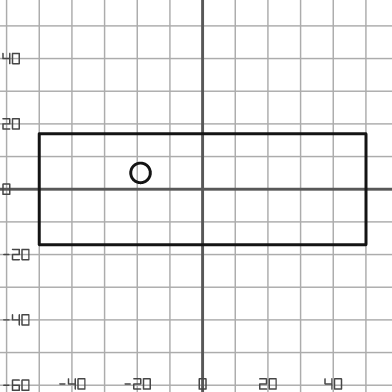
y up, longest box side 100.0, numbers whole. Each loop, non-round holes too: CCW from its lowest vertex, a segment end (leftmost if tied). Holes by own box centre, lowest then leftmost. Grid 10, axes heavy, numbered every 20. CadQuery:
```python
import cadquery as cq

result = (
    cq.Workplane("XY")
    .moveTo(-50.0, -17.0)
    .lineTo(50.0, -17.0)
    .lineTo(50.0, 17.0)
    .lineTo(-50.0, 17.0)
    .close()
    .moveTo(-19.0, 5.0)
    .circle(3.0)
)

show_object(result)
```